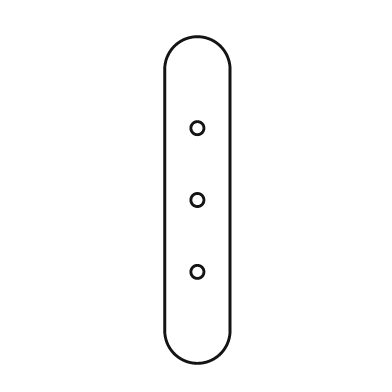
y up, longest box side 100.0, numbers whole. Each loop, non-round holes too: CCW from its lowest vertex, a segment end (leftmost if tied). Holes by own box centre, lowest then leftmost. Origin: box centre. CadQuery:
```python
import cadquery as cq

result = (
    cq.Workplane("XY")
    .moveTo(-10.0, -40.0)
    .threePointArc((0.0, -50.0), (10.0, -40.0))
    .lineTo(10.0, 40.0)
    .threePointArc((0.0, 50.0), (-10.0, 40.0))
    .close()
    .moveTo(0.0, -22.0)
    .circle(2.0)
    .moveTo(0.0, 0.0)
    .circle(2.0)
    .moveTo(0.0, 22.0)
    .circle(2.0)
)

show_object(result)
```